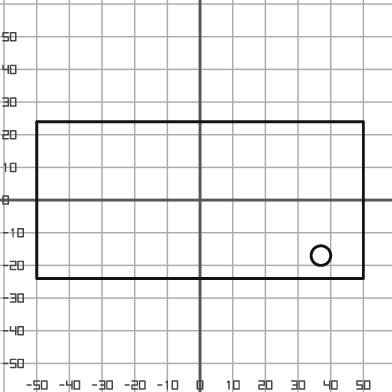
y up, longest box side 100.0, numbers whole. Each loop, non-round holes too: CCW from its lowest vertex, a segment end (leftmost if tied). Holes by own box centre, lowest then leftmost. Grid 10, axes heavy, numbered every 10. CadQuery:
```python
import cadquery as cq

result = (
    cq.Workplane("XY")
    .moveTo(-50.0, -24.0)
    .lineTo(50.0, -24.0)
    .lineTo(50.0, 24.0)
    .lineTo(-50.0, 24.0)
    .close()
    .moveTo(37.0, -17.0)
    .circle(3.0)
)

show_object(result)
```